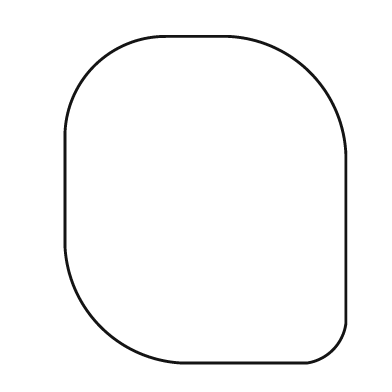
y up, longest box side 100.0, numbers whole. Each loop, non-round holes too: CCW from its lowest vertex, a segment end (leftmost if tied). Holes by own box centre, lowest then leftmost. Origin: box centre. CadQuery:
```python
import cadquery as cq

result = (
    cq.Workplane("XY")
    .moveTo(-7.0, -50.0)
    .lineTo(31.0, -50.0)
    .threePointArc((39.0, -46.0), (43.0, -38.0))
    .lineTo(43.0, 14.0)
    .threePointArc((32.0, 39.0), (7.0, 50.0))
    .lineTo(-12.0, 50.0)
    .threePointArc((-34.0, 41.0), (-43.0, 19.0))
    .lineTo(-43.0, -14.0)
    .threePointArc((-32.0, -39.0), (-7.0, -50.0))
    .close()
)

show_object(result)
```